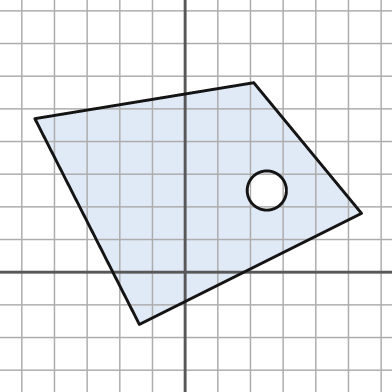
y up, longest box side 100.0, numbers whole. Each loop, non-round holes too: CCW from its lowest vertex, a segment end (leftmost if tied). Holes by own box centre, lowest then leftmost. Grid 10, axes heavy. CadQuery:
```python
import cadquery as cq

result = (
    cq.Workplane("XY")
    .moveTo(-14.0, -16.0)
    .lineTo(54.0, 18.0)
    .lineTo(21.0, 58.0)
    .lineTo(-46.0, 47.0)
    .close()
    .moveTo(25.0, 25.0)
    .circle(6.0)
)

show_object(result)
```